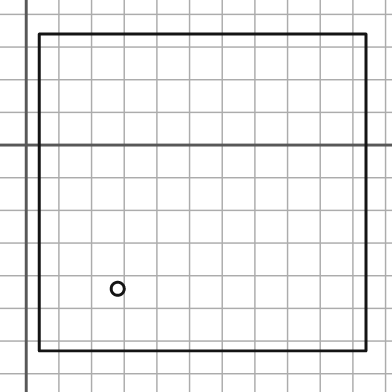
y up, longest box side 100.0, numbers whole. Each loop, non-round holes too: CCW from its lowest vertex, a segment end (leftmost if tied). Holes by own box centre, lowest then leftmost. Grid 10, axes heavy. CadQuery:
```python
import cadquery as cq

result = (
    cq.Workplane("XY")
    .moveTo(4.0, -63.0)
    .lineTo(104.0, -63.0)
    .lineTo(104.0, 34.0)
    .lineTo(4.0, 34.0)
    .close()
    .moveTo(28.0, -44.0)
    .circle(2.0)
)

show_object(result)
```